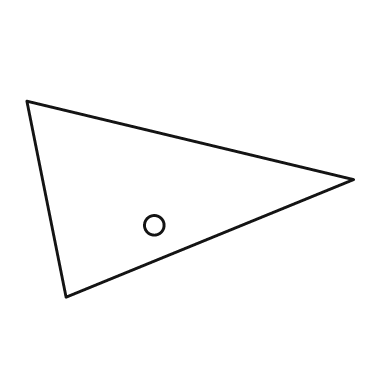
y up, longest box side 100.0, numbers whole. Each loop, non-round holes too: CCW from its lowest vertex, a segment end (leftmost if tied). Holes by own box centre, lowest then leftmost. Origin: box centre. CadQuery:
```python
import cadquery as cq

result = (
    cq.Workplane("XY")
    .moveTo(-38.0, -30.0)
    .lineTo(50.0, 6.0)
    .lineTo(-50.0, 30.0)
    .close()
    .moveTo(-11.0, -8.0)
    .circle(3.0)
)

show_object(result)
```